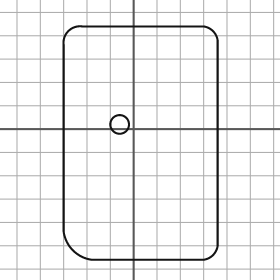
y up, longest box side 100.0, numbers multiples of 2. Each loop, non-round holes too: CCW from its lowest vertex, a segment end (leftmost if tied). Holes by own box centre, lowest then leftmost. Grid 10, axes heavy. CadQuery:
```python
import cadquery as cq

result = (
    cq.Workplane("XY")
    .moveTo(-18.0, -56.0)
    .lineTo(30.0, -56.0)
    .threePointArc((34.0, -54.0), (36.0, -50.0))
    .lineTo(36.0, 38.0)
    .threePointArc((34.0, 42.0), (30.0, 44.0))
    .lineTo(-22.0, 44.0)
    .threePointArc((-28.0, 42.0), (-30.0, 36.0))
    .lineTo(-30.0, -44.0)
    .threePointArc((-26.0, -52.0), (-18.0, -56.0))
    .close()
    .moveTo(-6.0, 2.0)
    .circle(4.0)
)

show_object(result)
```